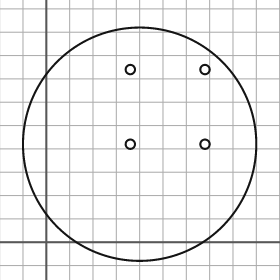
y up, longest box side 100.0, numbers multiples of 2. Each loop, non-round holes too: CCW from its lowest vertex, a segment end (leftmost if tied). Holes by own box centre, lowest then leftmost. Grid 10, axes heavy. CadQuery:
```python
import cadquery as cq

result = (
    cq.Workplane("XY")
    .moveTo(40.0, 42.0)
    .circle(50.0)
    .moveTo(36.0, 42.0)
    .circle(2.0)
    .moveTo(68.0, 42.0)
    .circle(2.0)
    .moveTo(36.0, 74.0)
    .circle(2.0)
    .moveTo(68.0, 74.0)
    .circle(2.0)
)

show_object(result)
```